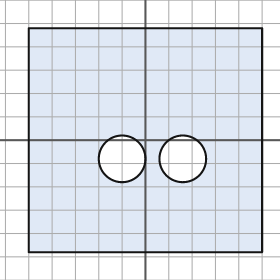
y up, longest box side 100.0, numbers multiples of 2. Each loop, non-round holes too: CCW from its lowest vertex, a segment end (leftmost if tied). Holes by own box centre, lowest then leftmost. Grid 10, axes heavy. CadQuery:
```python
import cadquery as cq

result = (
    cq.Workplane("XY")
    .moveTo(-50.0, -48.0)
    .lineTo(50.0, -48.0)
    .lineTo(50.0, 48.0)
    .lineTo(-50.0, 48.0)
    .close()
    .moveTo(-10.0, -8.0)
    .circle(10.0)
    .moveTo(16.0, -8.0)
    .circle(10.0)
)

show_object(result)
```